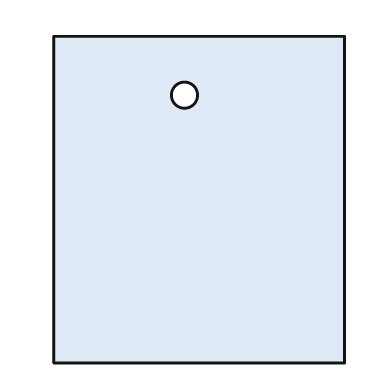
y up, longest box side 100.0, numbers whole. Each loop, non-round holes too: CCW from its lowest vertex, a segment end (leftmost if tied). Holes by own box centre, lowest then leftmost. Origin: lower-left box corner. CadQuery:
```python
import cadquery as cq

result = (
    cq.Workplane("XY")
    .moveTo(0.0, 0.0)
    .lineTo(89.0, 0.0)
    .lineTo(89.0, 100.0)
    .lineTo(0.0, 100.0)
    .close()
    .moveTo(40.0, 82.0)
    .circle(4.0)
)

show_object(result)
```